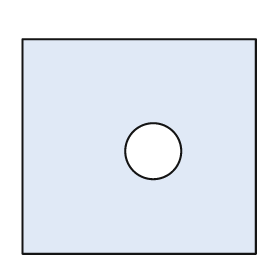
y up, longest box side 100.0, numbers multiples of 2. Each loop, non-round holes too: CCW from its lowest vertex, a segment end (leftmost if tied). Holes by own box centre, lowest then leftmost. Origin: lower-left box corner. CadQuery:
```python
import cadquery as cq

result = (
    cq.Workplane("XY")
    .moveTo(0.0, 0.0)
    .lineTo(100.0, 0.0)
    .lineTo(100.0, 92.0)
    .lineTo(0.0, 92.0)
    .close()
    .moveTo(56.0, 44.0)
    .circle(12.0)
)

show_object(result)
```